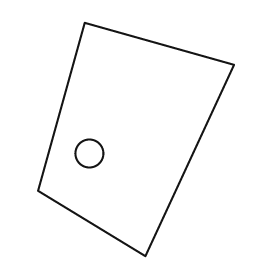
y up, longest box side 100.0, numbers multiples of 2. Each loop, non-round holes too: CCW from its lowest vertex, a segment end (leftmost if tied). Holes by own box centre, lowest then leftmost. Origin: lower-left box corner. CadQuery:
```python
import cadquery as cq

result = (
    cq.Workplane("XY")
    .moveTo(46.0, 0.0)
    .lineTo(84.0, 82.0)
    .lineTo(20.0, 100.0)
    .lineTo(0.0, 28.0)
    .close()
    .moveTo(22.0, 44.0)
    .circle(6.0)
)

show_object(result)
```